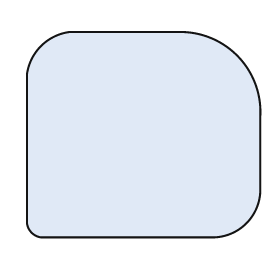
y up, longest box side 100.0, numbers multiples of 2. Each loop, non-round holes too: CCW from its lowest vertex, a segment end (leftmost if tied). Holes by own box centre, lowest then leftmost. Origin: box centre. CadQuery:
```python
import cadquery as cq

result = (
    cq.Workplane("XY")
    .moveTo(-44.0, -44.0)
    .lineTo(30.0, -44.0)
    .threePointArc((44.0, -38.0), (50.0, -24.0))
    .lineTo(50.0, 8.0)
    .threePointArc((40.0, 34.0), (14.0, 44.0))
    .lineTo(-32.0, 44.0)
    .threePointArc((-44.0, 38.0), (-50.0, 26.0))
    .lineTo(-50.0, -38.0)
    .threePointArc((-48.0, -42.0), (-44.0, -44.0))
    .close()
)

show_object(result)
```